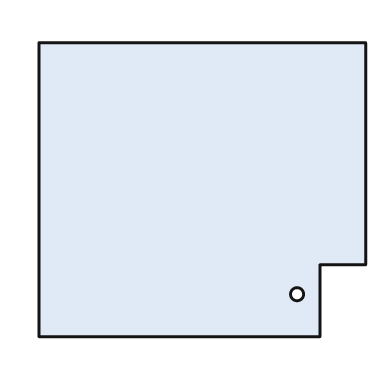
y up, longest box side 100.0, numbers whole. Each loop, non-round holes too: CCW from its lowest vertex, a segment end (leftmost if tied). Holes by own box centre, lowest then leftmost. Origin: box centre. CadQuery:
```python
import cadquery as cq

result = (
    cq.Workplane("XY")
    .moveTo(-50.0, -45.0)
    .lineTo(36.0, -45.0)
    .lineTo(36.0, -23.0)
    .lineTo(50.0, -23.0)
    .lineTo(50.0, 45.0)
    .lineTo(-50.0, 45.0)
    .close()
    .moveTo(29.0, -32.0)
    .circle(2.0)
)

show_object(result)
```